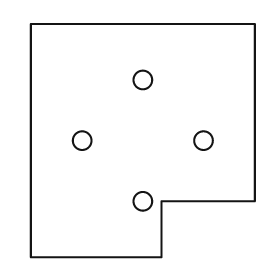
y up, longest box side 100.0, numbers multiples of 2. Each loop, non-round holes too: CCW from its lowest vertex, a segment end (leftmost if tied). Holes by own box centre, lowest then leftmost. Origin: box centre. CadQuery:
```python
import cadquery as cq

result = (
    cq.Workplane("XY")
    .moveTo(-48.0, -50.0)
    .lineTo(8.0, -50.0)
    .lineTo(8.0, -26.0)
    .lineTo(48.0, -26.0)
    .lineTo(48.0, 50.0)
    .lineTo(-48.0, 50.0)
    .close()
    .moveTo(0.0, -26.0)
    .circle(4.0)
    .moveTo(-26.0, 0.0)
    .circle(4.0)
    .moveTo(26.0, 0.0)
    .circle(4.0)
    .moveTo(0.0, 26.0)
    .circle(4.0)
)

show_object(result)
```